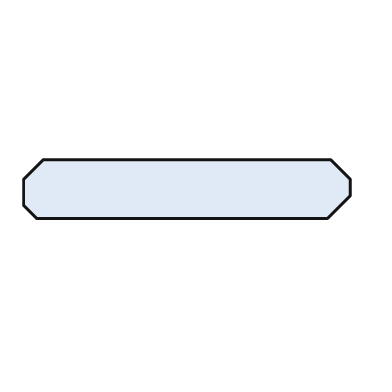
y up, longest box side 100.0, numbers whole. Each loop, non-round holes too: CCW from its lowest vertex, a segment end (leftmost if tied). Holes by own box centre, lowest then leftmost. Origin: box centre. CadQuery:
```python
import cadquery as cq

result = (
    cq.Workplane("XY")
    .moveTo(-46.0, -9.0)
    .lineTo(43.0, -9.0)
    .lineTo(50.0, -2.0)
    .lineTo(50.0, 3.0)
    .lineTo(44.0, 9.0)
    .lineTo(-44.0, 9.0)
    .lineTo(-50.0, 3.0)
    .lineTo(-50.0, -5.0)
    .close()
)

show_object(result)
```